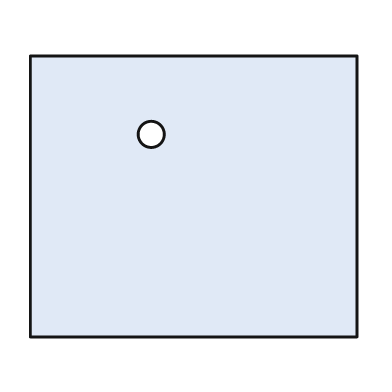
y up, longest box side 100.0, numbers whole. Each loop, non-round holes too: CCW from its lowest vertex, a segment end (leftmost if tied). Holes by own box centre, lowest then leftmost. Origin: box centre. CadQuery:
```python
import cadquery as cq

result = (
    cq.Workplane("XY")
    .moveTo(-50.0, -43.0)
    .lineTo(50.0, -43.0)
    .lineTo(50.0, 43.0)
    .lineTo(-50.0, 43.0)
    .close()
    .moveTo(-13.0, 19.0)
    .circle(4.0)
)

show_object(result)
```